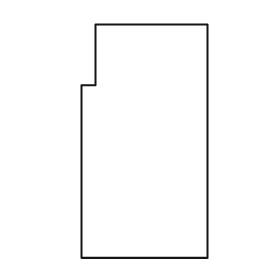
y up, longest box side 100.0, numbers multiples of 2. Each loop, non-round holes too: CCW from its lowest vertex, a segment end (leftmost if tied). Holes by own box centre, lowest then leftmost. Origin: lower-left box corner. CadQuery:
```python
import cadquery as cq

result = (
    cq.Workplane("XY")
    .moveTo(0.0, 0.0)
    .lineTo(54.0, 0.0)
    .lineTo(54.0, 100.0)
    .lineTo(6.0, 100.0)
    .lineTo(6.0, 74.0)
    .lineTo(0.0, 74.0)
    .close()
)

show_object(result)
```